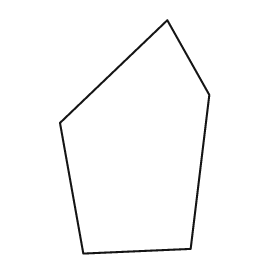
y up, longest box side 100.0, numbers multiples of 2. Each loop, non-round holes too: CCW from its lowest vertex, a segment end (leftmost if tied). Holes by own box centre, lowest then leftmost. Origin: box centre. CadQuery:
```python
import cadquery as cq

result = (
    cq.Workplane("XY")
    .moveTo(-22.0, -50.0)
    .lineTo(24.0, -48.0)
    .lineTo(32.0, 18.0)
    .lineTo(14.0, 50.0)
    .lineTo(-32.0, 6.0)
    .close()
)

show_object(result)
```